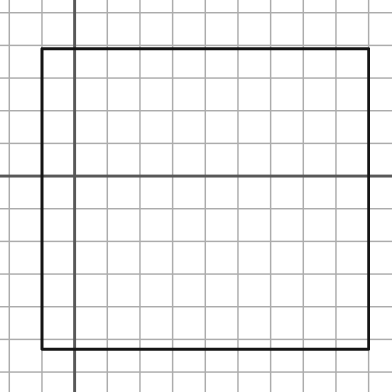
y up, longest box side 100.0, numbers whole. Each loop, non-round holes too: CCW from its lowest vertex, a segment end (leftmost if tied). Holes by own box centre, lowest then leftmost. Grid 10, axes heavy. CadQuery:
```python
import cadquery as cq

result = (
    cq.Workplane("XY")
    .moveTo(-10.0, -53.0)
    .lineTo(90.0, -53.0)
    .lineTo(90.0, 39.0)
    .lineTo(-10.0, 39.0)
    .close()
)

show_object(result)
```